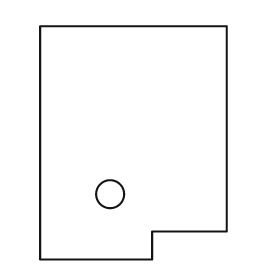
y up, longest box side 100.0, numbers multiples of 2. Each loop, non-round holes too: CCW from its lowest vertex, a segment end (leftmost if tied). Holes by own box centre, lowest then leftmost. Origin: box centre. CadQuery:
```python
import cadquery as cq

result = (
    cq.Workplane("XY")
    .moveTo(-40.0, -50.0)
    .lineTo(8.0, -50.0)
    .lineTo(8.0, -38.0)
    .lineTo(40.0, -38.0)
    .lineTo(40.0, 50.0)
    .lineTo(-40.0, 50.0)
    .close()
    .moveTo(-10.0, -22.0)
    .circle(6.0)
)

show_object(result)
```